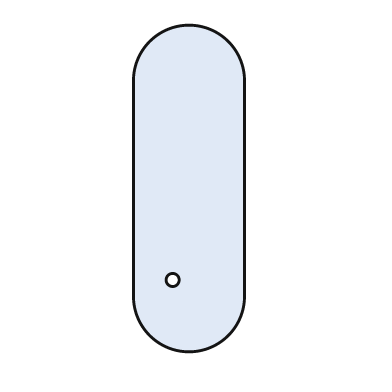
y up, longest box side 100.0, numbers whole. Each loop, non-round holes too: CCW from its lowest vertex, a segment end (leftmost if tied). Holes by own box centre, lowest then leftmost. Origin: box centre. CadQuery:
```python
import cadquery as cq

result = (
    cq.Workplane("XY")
    .moveTo(-17.0, -33.0)
    .threePointArc((0.0, -50.0), (17.0, -33.0))
    .lineTo(17.0, 33.0)
    .threePointArc((0.0, 50.0), (-17.0, 33.0))
    .close()
    .moveTo(-5.0, -28.0)
    .circle(2.0)
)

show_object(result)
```